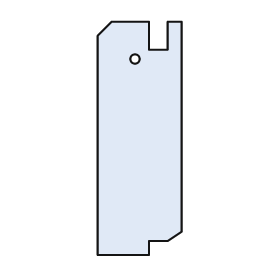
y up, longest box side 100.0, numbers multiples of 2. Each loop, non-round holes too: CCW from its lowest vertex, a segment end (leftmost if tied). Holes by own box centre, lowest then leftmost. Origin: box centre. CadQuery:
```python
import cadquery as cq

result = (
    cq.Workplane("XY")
    .moveTo(-18.0, -50.0)
    .lineTo(4.0, -50.0)
    .lineTo(4.0, -44.0)
    .lineTo(12.0, -44.0)
    .lineTo(18.0, -40.0)
    .lineTo(18.0, 50.0)
    .lineTo(12.0, 50.0)
    .lineTo(12.0, 38.0)
    .lineTo(4.0, 38.0)
    .lineTo(4.0, 50.0)
    .lineTo(-12.0, 50.0)
    .lineTo(-18.0, 44.0)
    .close()
    .moveTo(-2.0, 34.0)
    .circle(2.0)
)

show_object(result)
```